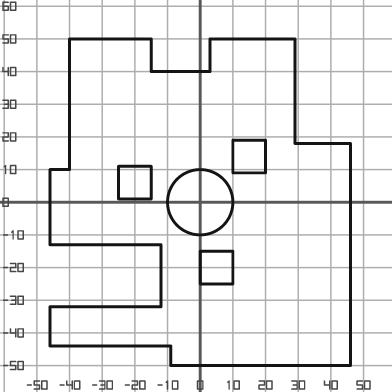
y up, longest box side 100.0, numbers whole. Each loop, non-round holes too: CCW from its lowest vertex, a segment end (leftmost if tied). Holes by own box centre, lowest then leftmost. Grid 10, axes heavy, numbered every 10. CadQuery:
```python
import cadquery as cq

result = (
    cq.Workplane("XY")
    .moveTo(-9.0, -50.0)
    .lineTo(46.0, -50.0)
    .lineTo(46.0, 18.0)
    .lineTo(29.0, 18.0)
    .lineTo(29.0, 50.0)
    .lineTo(3.0, 50.0)
    .lineTo(3.0, 40.0)
    .lineTo(-15.0, 40.0)
    .lineTo(-15.0, 50.0)
    .lineTo(-40.0, 50.0)
    .lineTo(-40.0, 10.0)
    .lineTo(-46.0, 10.0)
    .lineTo(-46.0, -13.0)
    .lineTo(-12.0, -13.0)
    .lineTo(-12.0, -32.0)
    .lineTo(-46.0, -32.0)
    .lineTo(-46.0, -44.0)
    .lineTo(-9.0, -44.0)
    .close()
    .moveTo(0.0, -25.0)
    .lineTo(10.0, -25.0)
    .lineTo(10.0, -15.0)
    .lineTo(0.0, -15.0)
    .close()
    .moveTo(0.0, 0.0)
    .circle(10.0)
    .moveTo(-25.0, 1.0)
    .lineTo(-15.0, 1.0)
    .lineTo(-15.0, 11.0)
    .lineTo(-25.0, 11.0)
    .close()
    .moveTo(10.0, 9.0)
    .lineTo(20.0, 9.0)
    .lineTo(20.0, 19.0)
    .lineTo(10.0, 19.0)
    .close()
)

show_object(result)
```